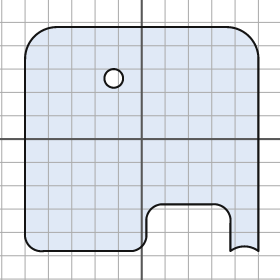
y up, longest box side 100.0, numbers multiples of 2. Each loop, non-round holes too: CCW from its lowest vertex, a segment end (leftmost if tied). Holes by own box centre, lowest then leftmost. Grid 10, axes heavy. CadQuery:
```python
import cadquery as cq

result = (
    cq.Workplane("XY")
    .moveTo(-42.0, -48.0)
    .lineTo(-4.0, -48.0)
    .threePointArc((0.0, -46.0), (2.0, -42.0))
    .lineTo(2.0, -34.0)
    .threePointArc((4.0, -30.0), (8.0, -28.0))
    .lineTo(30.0, -28.0)
    .threePointArc((36.0, -30.0), (38.0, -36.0))
    .lineTo(38.0, -48.0)
    .threePointArc((44.0, -46.0), (50.0, -48.0))
    .lineTo(50.0, 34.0)
    .threePointArc((46.0, 44.0), (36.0, 48.0))
    .lineTo(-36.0, 48.0)
    .threePointArc((-46.0, 44.0), (-50.0, 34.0))
    .lineTo(-50.0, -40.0)
    .threePointArc((-48.0, -46.0), (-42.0, -48.0))
    .close()
    .moveTo(-12.0, 26.0)
    .circle(4.0)
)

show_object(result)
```